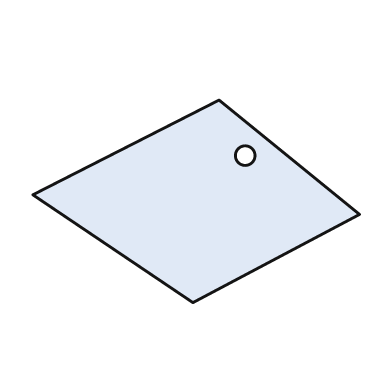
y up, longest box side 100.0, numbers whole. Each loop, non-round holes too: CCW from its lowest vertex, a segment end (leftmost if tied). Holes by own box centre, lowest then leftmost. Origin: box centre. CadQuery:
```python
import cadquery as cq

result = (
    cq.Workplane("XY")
    .moveTo(-1.0, -31.0)
    .lineTo(50.0, -4.0)
    .lineTo(7.0, 31.0)
    .lineTo(-50.0, 2.0)
    .close()
    .moveTo(15.0, 14.0)
    .circle(3.0)
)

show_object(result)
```